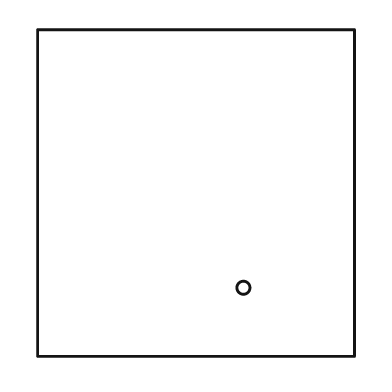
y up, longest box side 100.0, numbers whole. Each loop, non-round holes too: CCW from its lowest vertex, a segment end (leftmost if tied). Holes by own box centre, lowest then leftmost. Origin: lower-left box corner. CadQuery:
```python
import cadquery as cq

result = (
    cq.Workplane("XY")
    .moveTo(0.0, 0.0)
    .lineTo(97.0, 0.0)
    .lineTo(97.0, 100.0)
    .lineTo(0.0, 100.0)
    .close()
    .moveTo(63.0, 21.0)
    .circle(2.0)
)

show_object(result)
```